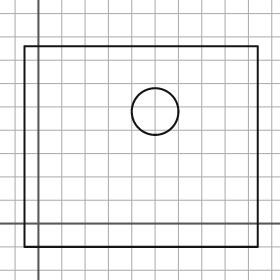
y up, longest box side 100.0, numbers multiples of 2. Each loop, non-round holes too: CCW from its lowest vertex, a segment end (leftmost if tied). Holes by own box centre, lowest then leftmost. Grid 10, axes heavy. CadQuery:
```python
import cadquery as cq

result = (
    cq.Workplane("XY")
    .moveTo(-6.0, -10.0)
    .lineTo(94.0, -10.0)
    .lineTo(94.0, 76.0)
    .lineTo(-6.0, 76.0)
    .close()
    .moveTo(50.0, 48.0)
    .circle(10.0)
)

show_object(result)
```